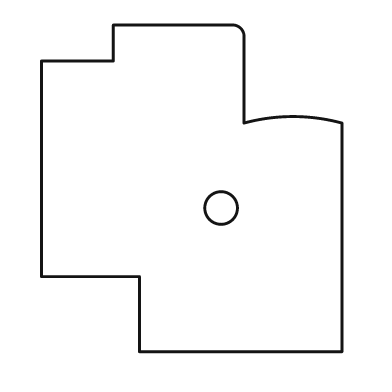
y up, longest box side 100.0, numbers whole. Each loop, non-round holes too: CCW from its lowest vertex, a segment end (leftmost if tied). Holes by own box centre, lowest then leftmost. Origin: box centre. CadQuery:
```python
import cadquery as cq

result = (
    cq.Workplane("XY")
    .moveTo(-16.0, -50.0)
    .lineTo(46.0, -50.0)
    .lineTo(46.0, 20.0)
    .threePointArc((31.0, 22.0), (16.0, 20.0))
    .lineTo(16.0, 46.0)
    .threePointArc((15.0, 49.0), (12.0, 50.0))
    .lineTo(-24.0, 50.0)
    .lineTo(-24.0, 39.0)
    .lineTo(-46.0, 39.0)
    .lineTo(-46.0, -27.0)
    .lineTo(-16.0, -27.0)
    .close()
    .moveTo(9.0, -6.0)
    .circle(5.0)
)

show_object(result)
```